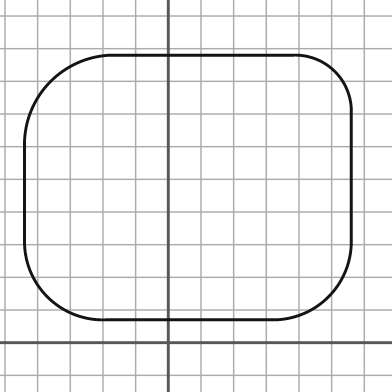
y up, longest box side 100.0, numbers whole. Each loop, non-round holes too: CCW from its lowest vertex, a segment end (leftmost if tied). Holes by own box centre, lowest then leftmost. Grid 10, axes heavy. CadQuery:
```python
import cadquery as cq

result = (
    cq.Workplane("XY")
    .moveTo(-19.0, 7.0)
    .lineTo(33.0, 7.0)
    .threePointArc((49.0, 14.0), (56.0, 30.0))
    .lineTo(56.0, 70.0)
    .threePointArc((51.0, 83.0), (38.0, 88.0))
    .lineTo(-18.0, 88.0)
    .threePointArc((-36.0, 80.0), (-44.0, 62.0))
    .lineTo(-44.0, 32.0)
    .threePointArc((-37.0, 14.0), (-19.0, 7.0))
    .close()
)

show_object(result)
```